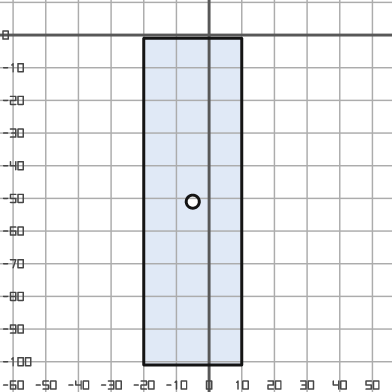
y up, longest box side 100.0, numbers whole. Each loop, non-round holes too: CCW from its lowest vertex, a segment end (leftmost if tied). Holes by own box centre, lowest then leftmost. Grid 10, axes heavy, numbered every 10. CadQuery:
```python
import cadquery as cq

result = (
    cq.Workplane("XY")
    .moveTo(-20.0, -101.0)
    .lineTo(10.0, -101.0)
    .lineTo(10.0, -1.0)
    .lineTo(-20.0, -1.0)
    .close()
    .moveTo(-5.0, -51.0)
    .circle(2.0)
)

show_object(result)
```